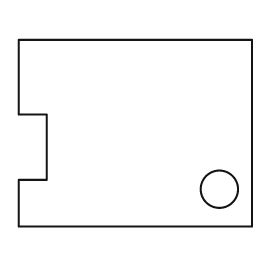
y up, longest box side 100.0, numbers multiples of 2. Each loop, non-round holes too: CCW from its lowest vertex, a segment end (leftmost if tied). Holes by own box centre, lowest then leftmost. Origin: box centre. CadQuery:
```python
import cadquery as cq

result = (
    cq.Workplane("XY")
    .moveTo(-50.0, -40.0)
    .lineTo(50.0, -40.0)
    .lineTo(50.0, 40.0)
    .lineTo(-50.0, 40.0)
    .lineTo(-50.0, 8.0)
    .lineTo(-38.0, 8.0)
    .lineTo(-38.0, -20.0)
    .lineTo(-50.0, -20.0)
    .close()
    .moveTo(36.0, -24.0)
    .circle(8.0)
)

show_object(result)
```